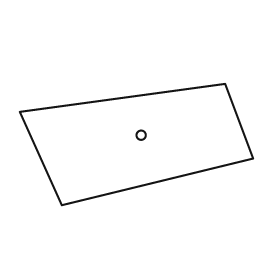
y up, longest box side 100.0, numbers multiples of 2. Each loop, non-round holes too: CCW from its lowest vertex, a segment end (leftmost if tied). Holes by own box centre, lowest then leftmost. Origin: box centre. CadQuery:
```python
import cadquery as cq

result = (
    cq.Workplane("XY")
    .moveTo(-32.0, -26.0)
    .lineTo(50.0, -6.0)
    .lineTo(38.0, 26.0)
    .lineTo(-50.0, 14.0)
    .close()
    .moveTo(2.0, 4.0)
    .circle(2.0)
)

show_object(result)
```